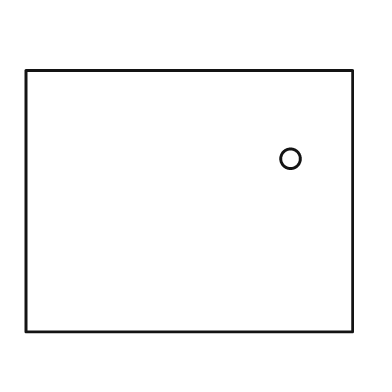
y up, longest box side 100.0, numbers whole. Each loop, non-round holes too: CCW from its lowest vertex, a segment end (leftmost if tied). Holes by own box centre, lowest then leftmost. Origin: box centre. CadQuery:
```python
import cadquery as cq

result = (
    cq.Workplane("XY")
    .moveTo(-50.0, -40.0)
    .lineTo(50.0, -40.0)
    .lineTo(50.0, 40.0)
    .lineTo(-50.0, 40.0)
    .close()
    .moveTo(31.0, 13.0)
    .circle(3.0)
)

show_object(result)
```